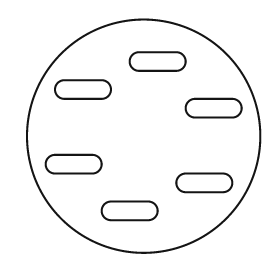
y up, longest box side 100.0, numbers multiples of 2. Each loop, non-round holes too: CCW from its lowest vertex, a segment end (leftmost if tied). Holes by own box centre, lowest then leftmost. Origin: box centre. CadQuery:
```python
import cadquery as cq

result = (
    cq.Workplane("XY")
    .moveTo(0.0, 0.0)
    .circle(50.0)
    .moveTo(-14.0, -36.0)
    .lineTo(2.0, -36.0)
    .threePointArc((6.0, -32.0), (2.0, -28.0))
    .lineTo(-14.0, -28.0)
    .threePointArc((-18.0, -32.0), (-14.0, -36.0))
    .close()
    .moveTo(18.0, -24.0)
    .lineTo(34.0, -24.0)
    .threePointArc((38.0, -20.0), (34.0, -16.0))
    .lineTo(18.0, -16.0)
    .threePointArc((14.0, -20.0), (18.0, -24.0))
    .close()
    .moveTo(-38.0, -16.0)
    .lineTo(-22.0, -16.0)
    .threePointArc((-18.0, -12.0), (-22.0, -8.0))
    .lineTo(-38.0, -8.0)
    .threePointArc((-42.0, -12.0), (-38.0, -16.0))
    .close()
    .moveTo(22.0, 8.0)
    .lineTo(38.0, 8.0)
    .threePointArc((42.0, 12.0), (38.0, 16.0))
    .lineTo(22.0, 16.0)
    .threePointArc((18.0, 12.0), (22.0, 8.0))
    .close()
    .moveTo(-34.0, 16.0)
    .lineTo(-18.0, 16.0)
    .threePointArc((-14.0, 20.0), (-18.0, 24.0))
    .lineTo(-34.0, 24.0)
    .threePointArc((-38.0, 20.0), (-34.0, 16.0))
    .close()
    .moveTo(-2.0, 28.0)
    .lineTo(14.0, 28.0)
    .threePointArc((18.0, 32.0), (14.0, 36.0))
    .lineTo(-2.0, 36.0)
    .threePointArc((-6.0, 32.0), (-2.0, 28.0))
    .close()
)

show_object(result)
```